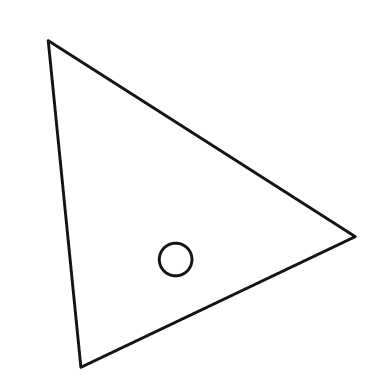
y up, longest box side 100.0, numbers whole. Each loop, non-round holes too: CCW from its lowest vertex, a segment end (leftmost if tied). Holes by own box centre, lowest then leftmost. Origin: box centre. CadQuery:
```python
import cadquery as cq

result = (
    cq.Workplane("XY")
    .moveTo(-37.0, -50.0)
    .lineTo(47.0, -10.0)
    .lineTo(-47.0, 50.0)
    .close()
    .moveTo(-8.0, -17.0)
    .circle(5.0)
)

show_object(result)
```